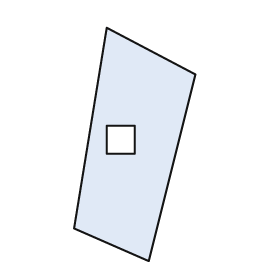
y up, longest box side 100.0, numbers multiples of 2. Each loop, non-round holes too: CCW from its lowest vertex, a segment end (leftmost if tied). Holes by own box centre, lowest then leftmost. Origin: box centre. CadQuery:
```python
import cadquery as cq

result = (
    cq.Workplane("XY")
    .moveTo(6.0, -50.0)
    .lineTo(26.0, 30.0)
    .lineTo(-12.0, 50.0)
    .lineTo(-26.0, -36.0)
    .close()
    .moveTo(-12.0, -4.0)
    .lineTo(0.0, -4.0)
    .lineTo(0.0, 8.0)
    .lineTo(-12.0, 8.0)
    .close()
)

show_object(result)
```